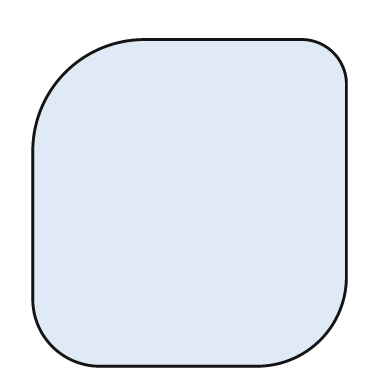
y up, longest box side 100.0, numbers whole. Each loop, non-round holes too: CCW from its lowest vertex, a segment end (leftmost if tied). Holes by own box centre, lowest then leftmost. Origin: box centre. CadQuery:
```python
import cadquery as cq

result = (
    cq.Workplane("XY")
    .moveTo(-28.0, -50.0)
    .lineTo(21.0, -50.0)
    .threePointArc((40.0, -42.0), (48.0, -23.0))
    .lineTo(48.0, 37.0)
    .threePointArc((44.0, 46.0), (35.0, 50.0))
    .lineTo(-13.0, 50.0)
    .threePointArc((-38.0, 40.0), (-48.0, 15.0))
    .lineTo(-48.0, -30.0)
    .threePointArc((-42.0, -44.0), (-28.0, -50.0))
    .close()
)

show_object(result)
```